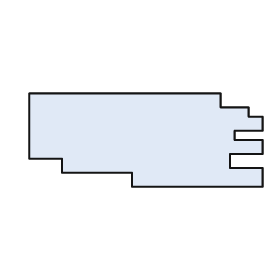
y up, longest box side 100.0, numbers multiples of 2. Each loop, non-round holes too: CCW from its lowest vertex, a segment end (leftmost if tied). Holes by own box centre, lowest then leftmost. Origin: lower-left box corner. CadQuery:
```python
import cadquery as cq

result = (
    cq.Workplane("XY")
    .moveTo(44.0, 0.0)
    .lineTo(100.0, 0.0)
    .lineTo(100.0, 8.0)
    .lineTo(86.0, 8.0)
    .lineTo(86.0, 14.0)
    .lineTo(100.0, 14.0)
    .lineTo(100.0, 20.0)
    .lineTo(88.0, 20.0)
    .lineTo(88.0, 24.0)
    .lineTo(100.0, 24.0)
    .lineTo(100.0, 30.0)
    .lineTo(94.0, 30.0)
    .lineTo(94.0, 34.0)
    .lineTo(82.0, 34.0)
    .lineTo(82.0, 40.0)
    .lineTo(0.0, 40.0)
    .lineTo(0.0, 12.0)
    .lineTo(14.0, 12.0)
    .lineTo(14.0, 6.0)
    .lineTo(44.0, 6.0)
    .close()
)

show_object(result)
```